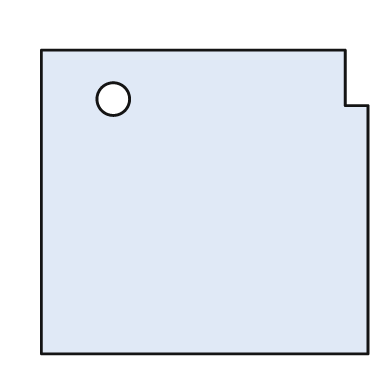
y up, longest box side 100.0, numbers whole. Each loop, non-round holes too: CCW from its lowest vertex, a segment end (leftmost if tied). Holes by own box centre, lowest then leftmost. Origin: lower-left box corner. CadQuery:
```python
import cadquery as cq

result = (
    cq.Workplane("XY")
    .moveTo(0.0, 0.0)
    .lineTo(100.0, 0.0)
    .lineTo(100.0, 76.0)
    .lineTo(93.0, 76.0)
    .lineTo(93.0, 93.0)
    .lineTo(0.0, 93.0)
    .close()
    .moveTo(22.0, 78.0)
    .circle(5.0)
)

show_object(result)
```